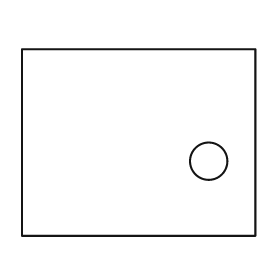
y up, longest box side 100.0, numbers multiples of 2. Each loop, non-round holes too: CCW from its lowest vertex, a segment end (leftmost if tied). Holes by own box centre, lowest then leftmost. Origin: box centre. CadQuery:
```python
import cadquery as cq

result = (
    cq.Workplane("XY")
    .moveTo(-50.0, -40.0)
    .lineTo(50.0, -40.0)
    .lineTo(50.0, 40.0)
    .lineTo(-50.0, 40.0)
    .close()
    .moveTo(30.0, -8.0)
    .circle(8.0)
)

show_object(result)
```